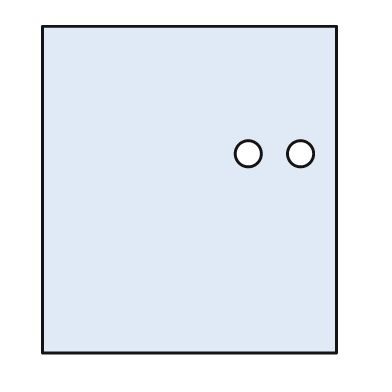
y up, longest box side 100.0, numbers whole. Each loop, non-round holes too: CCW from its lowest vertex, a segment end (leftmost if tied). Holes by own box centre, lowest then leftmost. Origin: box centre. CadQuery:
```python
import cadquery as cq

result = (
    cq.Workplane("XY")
    .moveTo(-45.0, -50.0)
    .lineTo(45.0, -50.0)
    .lineTo(45.0, 50.0)
    .lineTo(-45.0, 50.0)
    .close()
    .moveTo(18.0, 11.0)
    .circle(4.0)
    .moveTo(34.0, 11.0)
    .circle(4.0)
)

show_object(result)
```